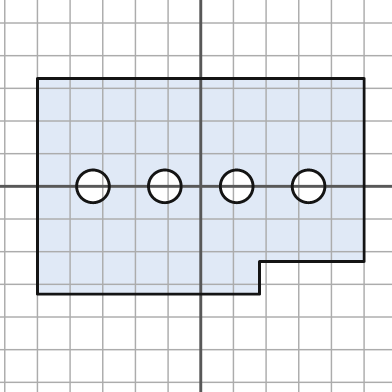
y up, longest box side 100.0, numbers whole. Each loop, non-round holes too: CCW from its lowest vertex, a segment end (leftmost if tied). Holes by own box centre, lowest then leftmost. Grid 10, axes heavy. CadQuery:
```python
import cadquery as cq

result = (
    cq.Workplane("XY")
    .moveTo(-50.0, -33.0)
    .lineTo(18.0, -33.0)
    .lineTo(18.0, -23.0)
    .lineTo(50.0, -23.0)
    .lineTo(50.0, 33.0)
    .lineTo(-50.0, 33.0)
    .close()
    .moveTo(-33.0, 0.0)
    .circle(5.0)
    .moveTo(-11.0, 0.0)
    .circle(5.0)
    .moveTo(11.0, 0.0)
    .circle(5.0)
    .moveTo(33.0, 0.0)
    .circle(5.0)
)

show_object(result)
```